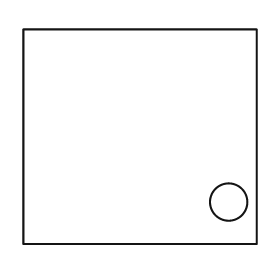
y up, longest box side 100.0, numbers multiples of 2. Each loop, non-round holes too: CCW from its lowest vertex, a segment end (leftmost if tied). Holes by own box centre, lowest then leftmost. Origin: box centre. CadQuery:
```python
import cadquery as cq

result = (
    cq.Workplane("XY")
    .moveTo(-50.0, -46.0)
    .lineTo(50.0, -46.0)
    .lineTo(50.0, 46.0)
    .lineTo(-50.0, 46.0)
    .close()
    .moveTo(38.0, -28.0)
    .circle(8.0)
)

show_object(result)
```